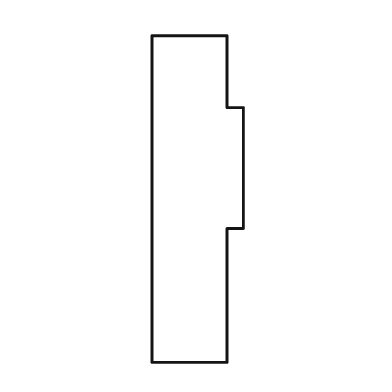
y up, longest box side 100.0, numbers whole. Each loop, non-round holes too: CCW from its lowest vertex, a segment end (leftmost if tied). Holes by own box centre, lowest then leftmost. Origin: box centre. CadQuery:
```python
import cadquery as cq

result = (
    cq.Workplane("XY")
    .moveTo(-14.0, -50.0)
    .lineTo(9.0, -50.0)
    .lineTo(9.0, -9.0)
    .lineTo(14.0, -9.0)
    .lineTo(14.0, 28.0)
    .lineTo(9.0, 28.0)
    .lineTo(9.0, 50.0)
    .lineTo(-14.0, 50.0)
    .close()
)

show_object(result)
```